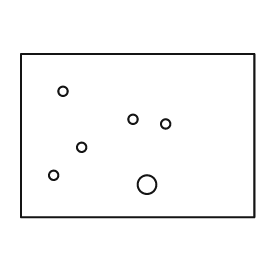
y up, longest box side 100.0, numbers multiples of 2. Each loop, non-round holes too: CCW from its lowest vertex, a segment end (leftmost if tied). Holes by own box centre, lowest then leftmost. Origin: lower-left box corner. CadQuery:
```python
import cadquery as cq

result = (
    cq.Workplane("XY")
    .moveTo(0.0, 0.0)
    .lineTo(100.0, 0.0)
    .lineTo(100.0, 70.0)
    .lineTo(0.0, 70.0)
    .close()
    .moveTo(54.0, 14.0)
    .circle(4.0)
    .moveTo(14.0, 18.0)
    .circle(2.0)
    .moveTo(26.0, 30.0)
    .circle(2.0)
    .moveTo(62.0, 40.0)
    .circle(2.0)
    .moveTo(48.0, 42.0)
    .circle(2.0)
    .moveTo(18.0, 54.0)
    .circle(2.0)
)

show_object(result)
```